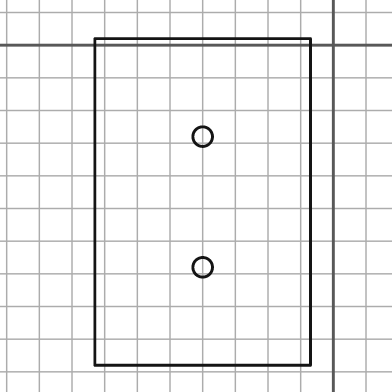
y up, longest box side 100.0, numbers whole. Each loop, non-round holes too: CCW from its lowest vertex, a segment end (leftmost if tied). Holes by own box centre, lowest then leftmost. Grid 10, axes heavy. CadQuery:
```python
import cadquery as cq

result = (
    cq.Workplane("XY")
    .moveTo(-73.0, -98.0)
    .lineTo(-7.0, -98.0)
    .lineTo(-7.0, 2.0)
    .lineTo(-73.0, 2.0)
    .close()
    .moveTo(-40.0, -68.0)
    .circle(3.0)
    .moveTo(-40.0, -28.0)
    .circle(3.0)
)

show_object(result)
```